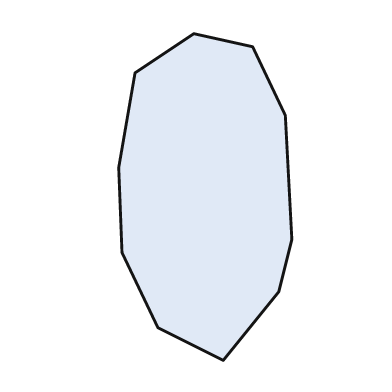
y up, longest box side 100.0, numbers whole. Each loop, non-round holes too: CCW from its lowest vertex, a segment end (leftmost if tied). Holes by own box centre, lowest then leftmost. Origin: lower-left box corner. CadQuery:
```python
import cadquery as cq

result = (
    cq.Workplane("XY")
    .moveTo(32.0, 0.0)
    .lineTo(49.0, 21.0)
    .lineTo(53.0, 37.0)
    .lineTo(51.0, 75.0)
    .lineTo(41.0, 96.0)
    .lineTo(23.0, 100.0)
    .lineTo(5.0, 88.0)
    .lineTo(0.0, 59.0)
    .lineTo(1.0, 33.0)
    .lineTo(12.0, 10.0)
    .close()
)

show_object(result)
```